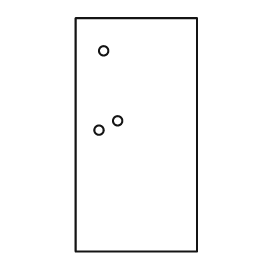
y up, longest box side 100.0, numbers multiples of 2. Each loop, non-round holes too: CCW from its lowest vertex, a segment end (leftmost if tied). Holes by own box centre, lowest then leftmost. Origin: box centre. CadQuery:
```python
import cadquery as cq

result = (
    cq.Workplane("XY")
    .moveTo(-26.0, -50.0)
    .lineTo(26.0, -50.0)
    .lineTo(26.0, 50.0)
    .lineTo(-26.0, 50.0)
    .close()
    .moveTo(-16.0, 2.0)
    .circle(2.0)
    .moveTo(-8.0, 6.0)
    .circle(2.0)
    .moveTo(-14.0, 36.0)
    .circle(2.0)
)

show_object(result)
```